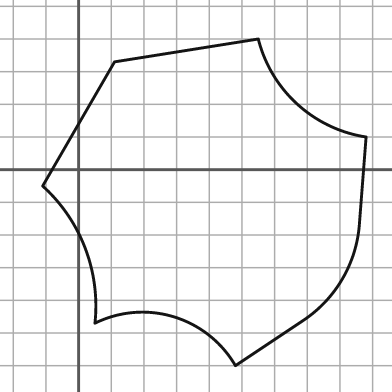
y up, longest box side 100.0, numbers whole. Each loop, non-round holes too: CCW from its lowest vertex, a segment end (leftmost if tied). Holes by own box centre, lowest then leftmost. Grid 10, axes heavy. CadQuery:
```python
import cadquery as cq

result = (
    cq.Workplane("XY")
    .moveTo(48.0, -60.0)
    .lineTo(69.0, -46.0)
    .threePointArc((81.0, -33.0), (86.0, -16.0))
    .lineTo(88.0, 10.0)
    .threePointArc((67.0, 20.0), (55.0, 40.0))
    .lineTo(11.0, 33.0)
    .lineTo(-11.0, -5.0)
    .threePointArc((2.0, -24.0), (5.0, -47.0))
    .threePointArc((29.0, -45.0), (48.0, -60.0))
    .close()
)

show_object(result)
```